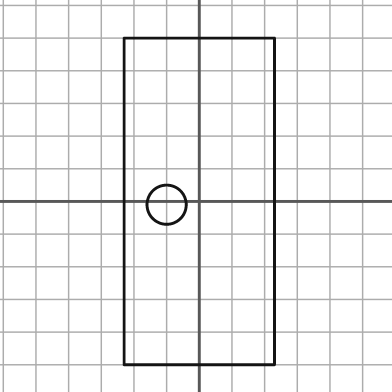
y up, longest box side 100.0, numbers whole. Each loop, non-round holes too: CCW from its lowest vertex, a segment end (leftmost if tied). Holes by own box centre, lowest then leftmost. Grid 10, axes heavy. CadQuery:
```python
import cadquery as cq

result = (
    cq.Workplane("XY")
    .moveTo(-23.0, -50.0)
    .lineTo(23.0, -50.0)
    .lineTo(23.0, 50.0)
    .lineTo(-23.0, 50.0)
    .close()
    .moveTo(-10.0, -1.0)
    .circle(6.0)
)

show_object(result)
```